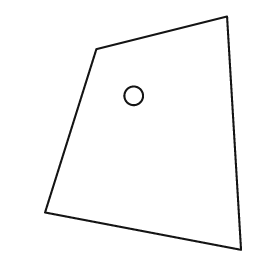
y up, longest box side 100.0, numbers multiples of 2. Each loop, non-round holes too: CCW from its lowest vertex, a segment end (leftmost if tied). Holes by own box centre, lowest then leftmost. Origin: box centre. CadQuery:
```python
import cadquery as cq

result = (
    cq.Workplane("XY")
    .moveTo(42.0, -50.0)
    .lineTo(36.0, 50.0)
    .lineTo(-20.0, 36.0)
    .lineTo(-42.0, -34.0)
    .close()
    .moveTo(-4.0, 16.0)
    .circle(4.0)
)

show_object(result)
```